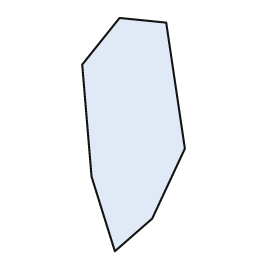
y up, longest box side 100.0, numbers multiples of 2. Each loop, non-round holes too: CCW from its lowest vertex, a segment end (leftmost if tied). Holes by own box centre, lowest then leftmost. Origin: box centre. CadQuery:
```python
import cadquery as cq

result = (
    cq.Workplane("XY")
    .moveTo(-8.0, -50.0)
    .lineTo(8.0, -36.0)
    .lineTo(22.0, -6.0)
    .lineTo(14.0, 48.0)
    .lineTo(-6.0, 50.0)
    .lineTo(-22.0, 30.0)
    .lineTo(-18.0, -18.0)
    .close()
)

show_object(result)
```